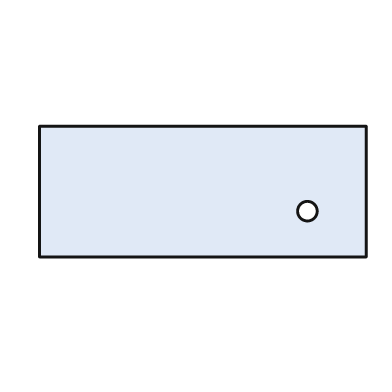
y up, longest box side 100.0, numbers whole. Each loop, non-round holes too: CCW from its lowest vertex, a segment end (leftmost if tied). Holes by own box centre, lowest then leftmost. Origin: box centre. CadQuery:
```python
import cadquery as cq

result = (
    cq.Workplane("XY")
    .moveTo(-50.0, -20.0)
    .lineTo(50.0, -20.0)
    .lineTo(50.0, 20.0)
    .lineTo(-50.0, 20.0)
    .close()
    .moveTo(32.0, -6.0)
    .circle(3.0)
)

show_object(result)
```